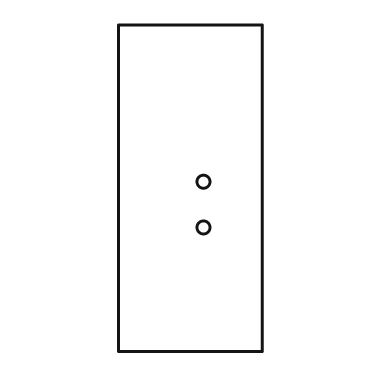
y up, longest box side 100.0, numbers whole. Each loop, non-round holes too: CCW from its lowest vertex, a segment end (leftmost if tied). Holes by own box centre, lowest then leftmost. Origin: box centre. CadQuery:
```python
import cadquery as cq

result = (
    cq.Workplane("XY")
    .moveTo(-22.0, -50.0)
    .lineTo(22.0, -50.0)
    .lineTo(22.0, 50.0)
    .lineTo(-22.0, 50.0)
    .close()
    .moveTo(4.0, -12.0)
    .circle(2.0)
    .moveTo(4.0, 2.0)
    .circle(2.0)
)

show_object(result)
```